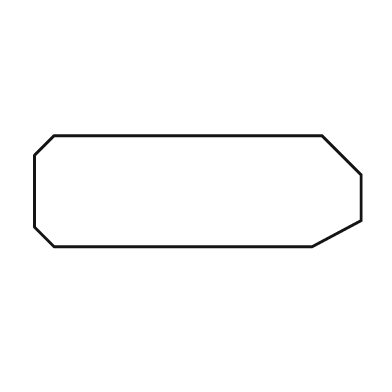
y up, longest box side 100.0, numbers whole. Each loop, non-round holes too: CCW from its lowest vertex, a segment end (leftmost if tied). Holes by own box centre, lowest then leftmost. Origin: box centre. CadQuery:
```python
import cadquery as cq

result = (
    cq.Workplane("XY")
    .moveTo(-44.0, -17.0)
    .lineTo(35.0, -17.0)
    .lineTo(50.0, -9.0)
    .lineTo(50.0, 5.0)
    .lineTo(38.0, 17.0)
    .lineTo(-44.0, 17.0)
    .lineTo(-50.0, 11.0)
    .lineTo(-50.0, -11.0)
    .close()
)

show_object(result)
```